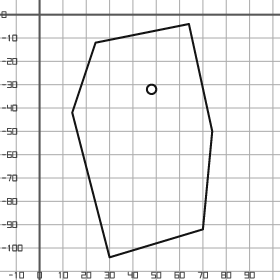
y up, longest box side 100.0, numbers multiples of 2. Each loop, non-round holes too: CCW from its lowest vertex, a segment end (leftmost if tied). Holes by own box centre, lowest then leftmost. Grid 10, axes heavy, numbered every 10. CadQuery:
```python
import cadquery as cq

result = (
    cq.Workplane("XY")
    .moveTo(30.0, -104.0)
    .lineTo(70.0, -92.0)
    .lineTo(74.0, -50.0)
    .lineTo(64.0, -4.0)
    .lineTo(24.0, -12.0)
    .lineTo(14.0, -42.0)
    .close()
    .moveTo(48.0, -32.0)
    .circle(2.0)
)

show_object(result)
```